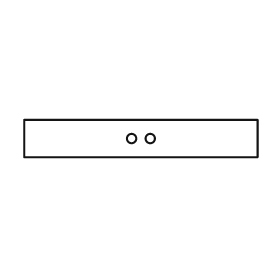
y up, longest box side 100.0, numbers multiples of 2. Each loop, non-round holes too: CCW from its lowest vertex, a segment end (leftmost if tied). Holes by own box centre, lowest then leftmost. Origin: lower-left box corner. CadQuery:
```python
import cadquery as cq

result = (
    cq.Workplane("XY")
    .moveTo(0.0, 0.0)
    .lineTo(100.0, 0.0)
    .lineTo(100.0, 16.0)
    .lineTo(0.0, 16.0)
    .close()
    .moveTo(46.0, 8.0)
    .circle(2.0)
    .moveTo(54.0, 8.0)
    .circle(2.0)
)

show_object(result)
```